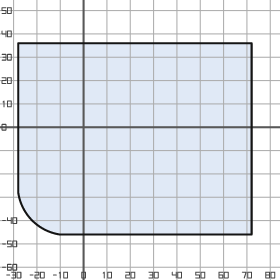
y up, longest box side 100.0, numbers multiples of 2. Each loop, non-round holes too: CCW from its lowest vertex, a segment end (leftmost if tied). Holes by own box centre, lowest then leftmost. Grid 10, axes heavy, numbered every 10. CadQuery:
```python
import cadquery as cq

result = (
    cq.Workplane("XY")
    .moveTo(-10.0, -46.0)
    .lineTo(72.0, -46.0)
    .lineTo(72.0, 36.0)
    .lineTo(-28.0, 36.0)
    .lineTo(-28.0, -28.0)
    .threePointArc((-22.0, -40.0), (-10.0, -46.0))
    .close()
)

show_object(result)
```